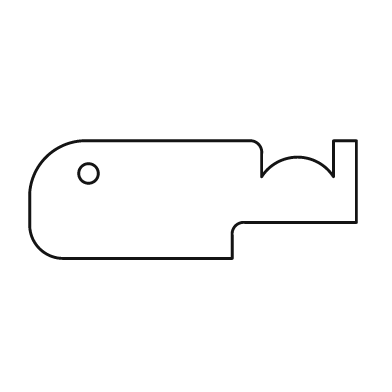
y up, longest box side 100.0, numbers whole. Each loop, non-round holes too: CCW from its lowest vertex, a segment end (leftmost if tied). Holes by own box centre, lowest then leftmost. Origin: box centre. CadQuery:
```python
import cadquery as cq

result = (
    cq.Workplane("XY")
    .moveTo(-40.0, -18.0)
    .lineTo(12.0, -18.0)
    .lineTo(12.0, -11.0)
    .threePointArc((13.0, -8.0), (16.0, -7.0))
    .lineTo(50.0, -7.0)
    .lineTo(50.0, 18.0)
    .lineTo(43.0, 18.0)
    .lineTo(43.0, 7.0)
    .threePointArc((32.0, 13.0), (21.0, 7.0))
    .lineTo(21.0, 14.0)
    .threePointArc((20.0, 17.0), (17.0, 18.0))
    .lineTo(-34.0, 18.0)
    .threePointArc((-45.0, 13.0), (-50.0, 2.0))
    .lineTo(-50.0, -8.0)
    .threePointArc((-47.0, -15.0), (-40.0, -18.0))
    .close()
    .moveTo(-32.0, 8.0)
    .circle(3.0)
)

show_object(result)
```